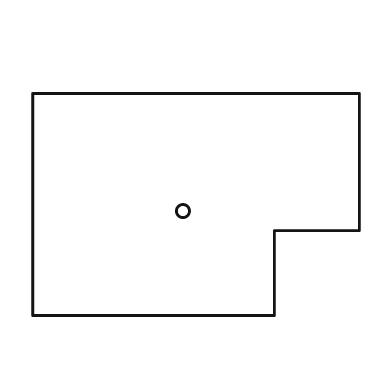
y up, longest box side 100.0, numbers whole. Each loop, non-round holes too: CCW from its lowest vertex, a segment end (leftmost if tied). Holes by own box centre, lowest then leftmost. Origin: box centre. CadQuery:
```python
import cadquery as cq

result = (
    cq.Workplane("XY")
    .moveTo(-50.0, -34.0)
    .lineTo(24.0, -34.0)
    .lineTo(24.0, -8.0)
    .lineTo(50.0, -8.0)
    .lineTo(50.0, 34.0)
    .lineTo(-50.0, 34.0)
    .close()
    .moveTo(-4.0, -2.0)
    .circle(2.0)
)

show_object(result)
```